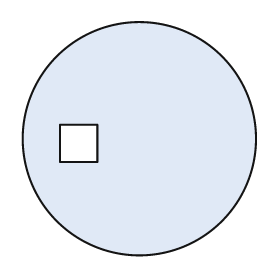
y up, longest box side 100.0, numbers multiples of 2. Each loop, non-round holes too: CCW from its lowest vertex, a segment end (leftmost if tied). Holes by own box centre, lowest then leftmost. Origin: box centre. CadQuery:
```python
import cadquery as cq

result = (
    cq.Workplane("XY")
    .moveTo(0.0, 0.0)
    .circle(50.0)
    .moveTo(-34.0, -10.0)
    .lineTo(-18.0, -10.0)
    .lineTo(-18.0, 6.0)
    .lineTo(-34.0, 6.0)
    .close()
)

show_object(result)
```